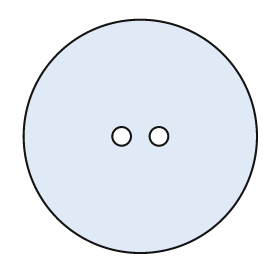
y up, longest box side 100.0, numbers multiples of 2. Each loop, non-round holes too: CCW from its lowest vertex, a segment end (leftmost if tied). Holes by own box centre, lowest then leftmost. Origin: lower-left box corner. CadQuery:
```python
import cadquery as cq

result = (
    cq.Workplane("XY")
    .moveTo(50.0, 50.0)
    .circle(50.0)
    .moveTo(42.0, 50.0)
    .circle(4.0)
    .moveTo(58.0, 50.0)
    .circle(4.0)
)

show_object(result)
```